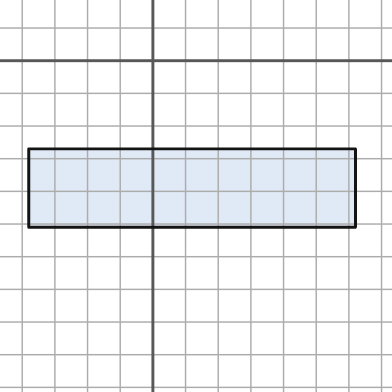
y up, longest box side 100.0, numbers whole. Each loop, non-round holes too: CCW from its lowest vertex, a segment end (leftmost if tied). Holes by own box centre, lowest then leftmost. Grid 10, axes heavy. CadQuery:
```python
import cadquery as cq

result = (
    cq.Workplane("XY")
    .moveTo(-38.0, -51.0)
    .lineTo(62.0, -51.0)
    .lineTo(62.0, -27.0)
    .lineTo(-38.0, -27.0)
    .close()
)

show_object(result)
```